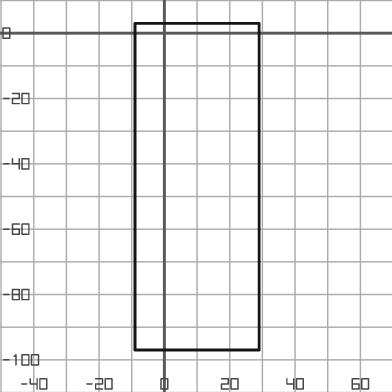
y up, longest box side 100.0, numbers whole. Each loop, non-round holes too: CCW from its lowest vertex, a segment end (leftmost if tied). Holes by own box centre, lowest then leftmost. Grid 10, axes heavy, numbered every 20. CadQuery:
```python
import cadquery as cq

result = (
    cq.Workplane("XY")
    .moveTo(-9.0, -97.0)
    .lineTo(29.0, -97.0)
    .lineTo(29.0, 3.0)
    .lineTo(-9.0, 3.0)
    .close()
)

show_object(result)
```